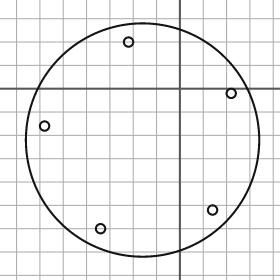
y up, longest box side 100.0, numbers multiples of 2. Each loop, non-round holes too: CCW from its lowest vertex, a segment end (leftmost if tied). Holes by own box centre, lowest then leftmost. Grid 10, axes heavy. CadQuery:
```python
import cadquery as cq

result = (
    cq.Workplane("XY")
    .moveTo(-16.0, -22.0)
    .circle(50.0)
    .moveTo(-34.0, -60.0)
    .circle(2.0)
    .moveTo(14.0, -52.0)
    .circle(2.0)
    .moveTo(-58.0, -16.0)
    .circle(2.0)
    .moveTo(22.0, -2.0)
    .circle(2.0)
    .moveTo(-22.0, 20.0)
    .circle(2.0)
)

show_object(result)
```